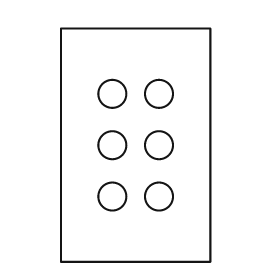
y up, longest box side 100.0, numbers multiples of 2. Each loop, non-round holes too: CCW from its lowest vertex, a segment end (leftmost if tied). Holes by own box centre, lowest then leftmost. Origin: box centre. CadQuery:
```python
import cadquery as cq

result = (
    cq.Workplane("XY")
    .moveTo(-32.0, -50.0)
    .lineTo(32.0, -50.0)
    .lineTo(32.0, 50.0)
    .lineTo(-32.0, 50.0)
    .close()
    .moveTo(-10.0, -22.0)
    .circle(6.0)
    .moveTo(10.0, -22.0)
    .circle(6.0)
    .moveTo(-10.0, 0.0)
    .circle(6.0)
    .moveTo(10.0, 0.0)
    .circle(6.0)
    .moveTo(-10.0, 22.0)
    .circle(6.0)
    .moveTo(10.0, 22.0)
    .circle(6.0)
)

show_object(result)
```